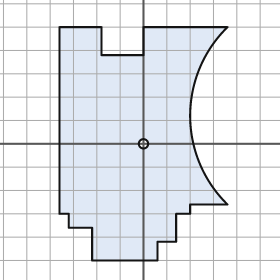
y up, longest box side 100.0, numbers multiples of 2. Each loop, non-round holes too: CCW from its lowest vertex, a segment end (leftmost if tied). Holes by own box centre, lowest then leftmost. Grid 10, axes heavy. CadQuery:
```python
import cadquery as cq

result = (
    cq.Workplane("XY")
    .moveTo(-22.0, -50.0)
    .lineTo(6.0, -50.0)
    .lineTo(6.0, -42.0)
    .lineTo(14.0, -42.0)
    .lineTo(14.0, -30.0)
    .lineTo(20.0, -30.0)
    .lineTo(20.0, -26.0)
    .lineTo(36.0, -26.0)
    .threePointArc((20.0, 12.0), (36.0, 50.0))
    .lineTo(0.0, 50.0)
    .lineTo(0.0, 38.0)
    .lineTo(-18.0, 38.0)
    .lineTo(-18.0, 50.0)
    .lineTo(-36.0, 50.0)
    .lineTo(-36.0, -30.0)
    .lineTo(-32.0, -30.0)
    .lineTo(-32.0, -36.0)
    .lineTo(-22.0, -36.0)
    .close()
    .moveTo(0.0, 0.0)
    .circle(2.0)
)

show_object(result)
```